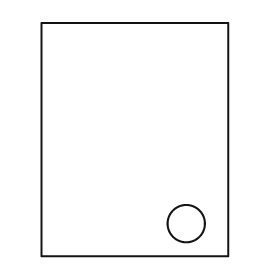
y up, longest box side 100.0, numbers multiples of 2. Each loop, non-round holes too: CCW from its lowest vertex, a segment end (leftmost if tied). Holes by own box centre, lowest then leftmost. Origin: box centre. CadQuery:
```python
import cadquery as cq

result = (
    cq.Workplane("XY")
    .moveTo(-40.0, -50.0)
    .lineTo(40.0, -50.0)
    .lineTo(40.0, 50.0)
    .lineTo(-40.0, 50.0)
    .close()
    .moveTo(22.0, -36.0)
    .circle(8.0)
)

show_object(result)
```